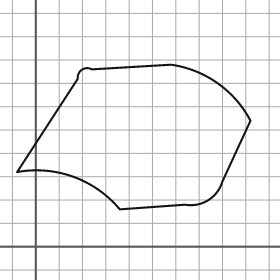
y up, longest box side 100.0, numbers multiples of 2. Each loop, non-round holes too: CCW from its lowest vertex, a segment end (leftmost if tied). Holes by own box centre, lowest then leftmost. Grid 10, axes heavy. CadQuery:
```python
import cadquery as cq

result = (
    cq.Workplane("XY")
    .moveTo(36.0, 16.0)
    .lineTo(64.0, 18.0)
    .threePointArc((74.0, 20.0), (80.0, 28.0))
    .lineTo(92.0, 54.0)
    .threePointArc((78.0, 70.0), (58.0, 78.0))
    .lineTo(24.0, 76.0)
    .threePointArc((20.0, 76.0), (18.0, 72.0))
    .lineTo(-8.0, 32.0)
    .threePointArc((16.0, 30.0), (36.0, 16.0))
    .close()
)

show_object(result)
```